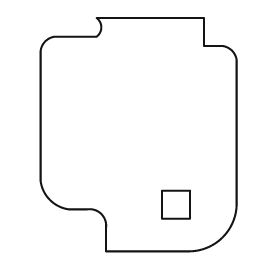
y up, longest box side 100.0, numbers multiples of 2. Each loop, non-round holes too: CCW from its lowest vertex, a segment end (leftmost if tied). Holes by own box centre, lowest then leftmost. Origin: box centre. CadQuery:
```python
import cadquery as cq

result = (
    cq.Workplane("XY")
    .moveTo(-14.0, -50.0)
    .lineTo(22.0, -50.0)
    .threePointArc((36.0, -44.0), (42.0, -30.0))
    .lineTo(42.0, 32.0)
    .threePointArc((40.0, 36.0), (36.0, 38.0))
    .lineTo(28.0, 38.0)
    .lineTo(28.0, 50.0)
    .lineTo(-18.0, 50.0)
    .threePointArc((-16.0, 46.0), (-18.0, 42.0))
    .lineTo(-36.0, 42.0)
    .threePointArc((-40.0, 40.0), (-42.0, 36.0))
    .lineTo(-42.0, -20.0)
    .threePointArc((-38.0, -28.0), (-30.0, -32.0))
    .lineTo(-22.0, -32.0)
    .threePointArc((-16.0, -34.0), (-14.0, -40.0))
    .close()
    .moveTo(10.0, -36.0)
    .lineTo(22.0, -36.0)
    .lineTo(22.0, -24.0)
    .lineTo(10.0, -24.0)
    .close()
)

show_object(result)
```